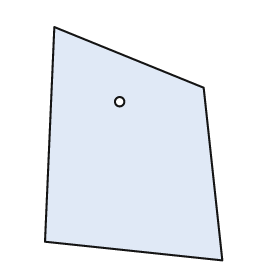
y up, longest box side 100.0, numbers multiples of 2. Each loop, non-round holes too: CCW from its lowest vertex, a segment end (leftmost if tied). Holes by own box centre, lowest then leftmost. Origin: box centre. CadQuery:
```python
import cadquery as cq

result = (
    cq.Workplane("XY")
    .moveTo(38.0, -50.0)
    .lineTo(30.0, 24.0)
    .lineTo(-34.0, 50.0)
    .lineTo(-38.0, -42.0)
    .close()
    .moveTo(-6.0, 18.0)
    .circle(2.0)
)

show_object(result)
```